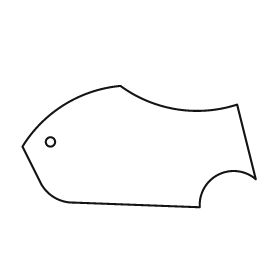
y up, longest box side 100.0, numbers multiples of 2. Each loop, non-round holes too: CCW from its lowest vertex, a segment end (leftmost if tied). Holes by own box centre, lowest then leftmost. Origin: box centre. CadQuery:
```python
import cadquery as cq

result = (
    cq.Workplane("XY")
    .moveTo(26.0, -26.0)
    .threePointArc((34.0, -12.0), (50.0, -14.0))
    .lineTo(42.0, 18.0)
    .threePointArc((16.0, 16.0), (-8.0, 26.0))
    .threePointArc((-32.0, 18.0), (-50.0, 0.0))
    .lineTo(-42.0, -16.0)
    .threePointArc((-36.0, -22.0), (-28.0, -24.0))
    .close()
    .moveTo(-38.0, 2.0)
    .circle(2.0)
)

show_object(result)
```